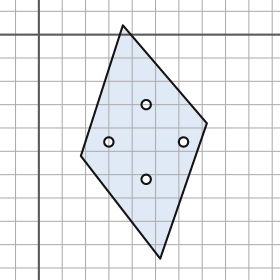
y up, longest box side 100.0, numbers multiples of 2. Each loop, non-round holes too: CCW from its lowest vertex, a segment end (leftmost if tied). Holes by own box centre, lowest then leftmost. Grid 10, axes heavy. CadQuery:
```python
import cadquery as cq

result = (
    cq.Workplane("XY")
    .moveTo(52.0, -96.0)
    .lineTo(72.0, -38.0)
    .lineTo(36.0, 4.0)
    .lineTo(18.0, -52.0)
    .close()
    .moveTo(46.0, -62.0)
    .circle(2.0)
    .moveTo(30.0, -46.0)
    .circle(2.0)
    .moveTo(62.0, -46.0)
    .circle(2.0)
    .moveTo(46.0, -30.0)
    .circle(2.0)
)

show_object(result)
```